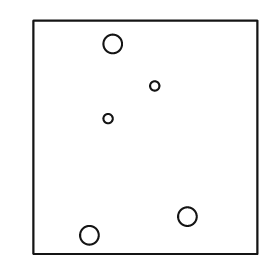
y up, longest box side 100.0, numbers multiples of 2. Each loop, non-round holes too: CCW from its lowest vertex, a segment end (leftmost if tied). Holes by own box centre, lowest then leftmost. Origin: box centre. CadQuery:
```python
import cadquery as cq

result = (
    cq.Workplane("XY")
    .moveTo(-48.0, -50.0)
    .lineTo(48.0, -50.0)
    .lineTo(48.0, 50.0)
    .lineTo(-48.0, 50.0)
    .close()
    .moveTo(-24.0, -42.0)
    .circle(4.0)
    .moveTo(18.0, -34.0)
    .circle(4.0)
    .moveTo(-16.0, 8.0)
    .circle(2.0)
    .moveTo(4.0, 22.0)
    .circle(2.0)
    .moveTo(-14.0, 40.0)
    .circle(4.0)
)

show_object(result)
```